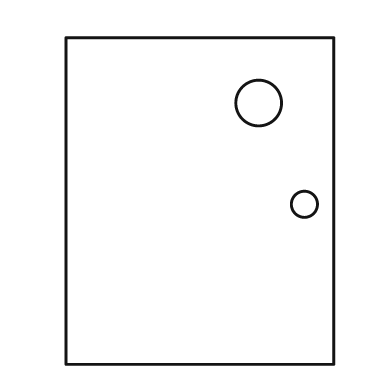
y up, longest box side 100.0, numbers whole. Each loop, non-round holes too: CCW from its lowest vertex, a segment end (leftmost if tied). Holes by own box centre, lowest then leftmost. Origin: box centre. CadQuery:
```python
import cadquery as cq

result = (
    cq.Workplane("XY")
    .moveTo(-41.0, -50.0)
    .lineTo(41.0, -50.0)
    .lineTo(41.0, 50.0)
    .lineTo(-41.0, 50.0)
    .close()
    .moveTo(32.0, -1.0)
    .circle(4.0)
    .moveTo(18.0, 30.0)
    .circle(7.0)
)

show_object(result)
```